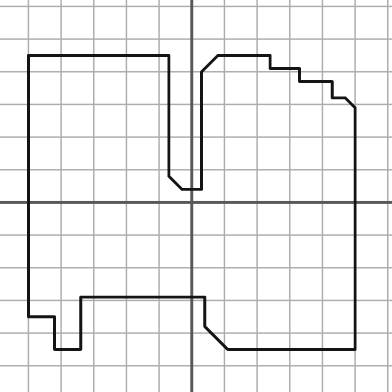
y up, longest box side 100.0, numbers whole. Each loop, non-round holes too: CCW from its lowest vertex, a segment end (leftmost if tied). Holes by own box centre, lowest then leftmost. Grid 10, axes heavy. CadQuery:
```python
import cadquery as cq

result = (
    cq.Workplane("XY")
    .moveTo(-42.0, -45.0)
    .lineTo(-34.0, -45.0)
    .lineTo(-34.0, -29.0)
    .lineTo(4.0, -29.0)
    .lineTo(4.0, -38.0)
    .lineTo(11.0, -45.0)
    .lineTo(50.0, -45.0)
    .lineTo(50.0, 29.0)
    .lineTo(47.0, 32.0)
    .lineTo(43.0, 32.0)
    .lineTo(43.0, 37.0)
    .lineTo(33.0, 37.0)
    .lineTo(33.0, 41.0)
    .lineTo(24.0, 41.0)
    .lineTo(24.0, 45.0)
    .lineTo(8.0, 45.0)
    .lineTo(3.0, 40.0)
    .lineTo(3.0, 4.0)
    .lineTo(-3.0, 4.0)
    .lineTo(-7.0, 8.0)
    .lineTo(-7.0, 45.0)
    .lineTo(-50.0, 45.0)
    .lineTo(-50.0, -35.0)
    .lineTo(-42.0, -35.0)
    .close()
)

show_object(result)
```